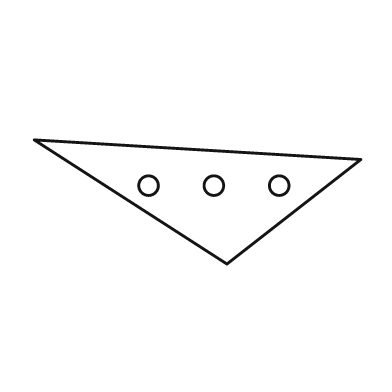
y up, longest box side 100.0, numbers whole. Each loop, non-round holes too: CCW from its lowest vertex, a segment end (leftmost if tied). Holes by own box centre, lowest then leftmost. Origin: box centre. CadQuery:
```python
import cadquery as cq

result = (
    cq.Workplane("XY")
    .moveTo(9.0, -19.0)
    .lineTo(50.0, 13.0)
    .lineTo(-50.0, 19.0)
    .close()
    .moveTo(-15.0, 5.0)
    .circle(3.0)
    .moveTo(5.0, 5.0)
    .circle(3.0)
    .moveTo(25.0, 5.0)
    .circle(3.0)
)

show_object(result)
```